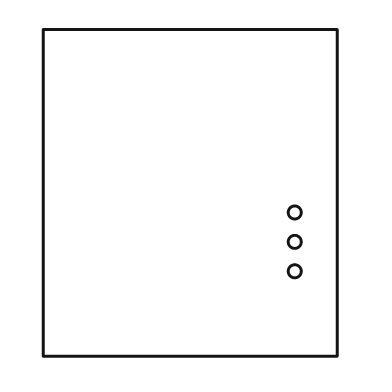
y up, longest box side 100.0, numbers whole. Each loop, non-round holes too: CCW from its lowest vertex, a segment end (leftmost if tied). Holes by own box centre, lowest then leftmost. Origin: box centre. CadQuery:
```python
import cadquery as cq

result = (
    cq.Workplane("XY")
    .moveTo(-45.0, -50.0)
    .lineTo(45.0, -50.0)
    .lineTo(45.0, 50.0)
    .lineTo(-45.0, 50.0)
    .close()
    .moveTo(32.0, -24.0)
    .circle(2.0)
    .moveTo(32.0, -15.0)
    .circle(2.0)
    .moveTo(32.0, -6.0)
    .circle(2.0)
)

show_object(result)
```